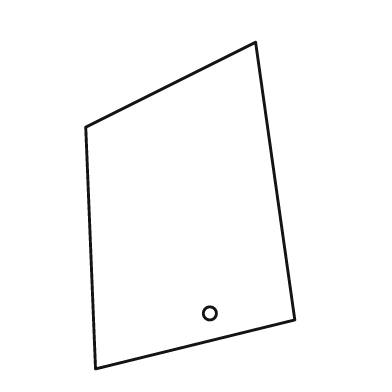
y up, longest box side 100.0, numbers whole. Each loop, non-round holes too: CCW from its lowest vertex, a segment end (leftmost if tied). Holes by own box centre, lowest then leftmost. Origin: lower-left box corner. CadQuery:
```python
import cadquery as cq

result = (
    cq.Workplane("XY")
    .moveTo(3.0, 0.0)
    .lineTo(64.0, 15.0)
    .lineTo(52.0, 100.0)
    .lineTo(0.0, 74.0)
    .close()
    .moveTo(38.0, 17.0)
    .circle(2.0)
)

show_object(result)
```